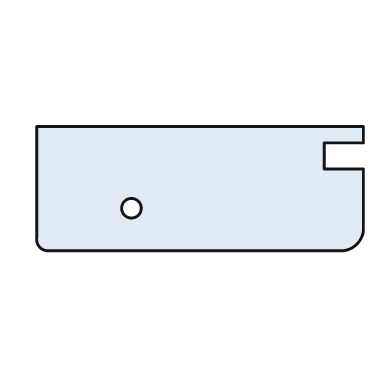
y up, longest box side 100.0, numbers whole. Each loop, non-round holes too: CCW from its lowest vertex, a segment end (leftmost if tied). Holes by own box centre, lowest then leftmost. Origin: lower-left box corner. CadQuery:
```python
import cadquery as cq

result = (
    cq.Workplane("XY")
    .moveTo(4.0, 0.0)
    .lineTo(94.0, 0.0)
    .threePointArc((98.0, 2.0), (100.0, 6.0))
    .lineTo(100.0, 25.0)
    .lineTo(88.0, 25.0)
    .lineTo(88.0, 33.0)
    .lineTo(100.0, 33.0)
    .lineTo(100.0, 38.0)
    .lineTo(0.0, 38.0)
    .lineTo(0.0, 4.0)
    .threePointArc((1.0, 1.0), (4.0, 0.0))
    .close()
    .moveTo(29.0, 13.0)
    .circle(3.0)
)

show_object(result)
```